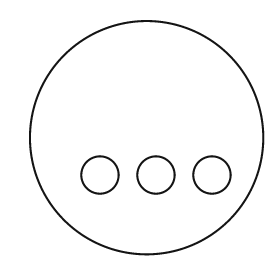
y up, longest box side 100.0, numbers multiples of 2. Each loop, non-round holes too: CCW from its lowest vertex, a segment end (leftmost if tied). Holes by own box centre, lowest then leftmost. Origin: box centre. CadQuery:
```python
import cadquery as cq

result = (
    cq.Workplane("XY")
    .moveTo(0.0, 0.0)
    .circle(50.0)
    .moveTo(-20.0, -16.0)
    .circle(8.0)
    .moveTo(4.0, -16.0)
    .circle(8.0)
    .moveTo(28.0, -16.0)
    .circle(8.0)
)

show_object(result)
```